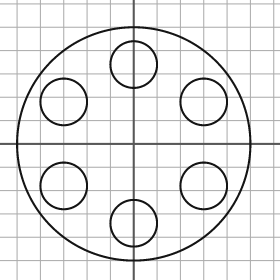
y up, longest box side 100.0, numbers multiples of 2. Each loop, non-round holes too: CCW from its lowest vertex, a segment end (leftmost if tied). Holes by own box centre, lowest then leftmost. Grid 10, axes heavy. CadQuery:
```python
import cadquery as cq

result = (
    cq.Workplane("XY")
    .moveTo(0.0, 0.0)
    .circle(50.0)
    .moveTo(0.0, -34.0)
    .circle(10.0)
    .moveTo(-30.0, -18.0)
    .circle(10.0)
    .moveTo(30.0, -18.0)
    .circle(10.0)
    .moveTo(-30.0, 18.0)
    .circle(10.0)
    .moveTo(30.0, 18.0)
    .circle(10.0)
    .moveTo(0.0, 34.0)
    .circle(10.0)
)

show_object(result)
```